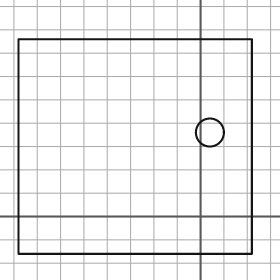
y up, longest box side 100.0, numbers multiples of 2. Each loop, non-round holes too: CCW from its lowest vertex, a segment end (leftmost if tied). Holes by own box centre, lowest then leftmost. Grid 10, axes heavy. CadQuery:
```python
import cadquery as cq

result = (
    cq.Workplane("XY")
    .moveTo(-78.0, -16.0)
    .lineTo(22.0, -16.0)
    .lineTo(22.0, 76.0)
    .lineTo(-78.0, 76.0)
    .close()
    .moveTo(4.0, 36.0)
    .circle(6.0)
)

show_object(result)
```